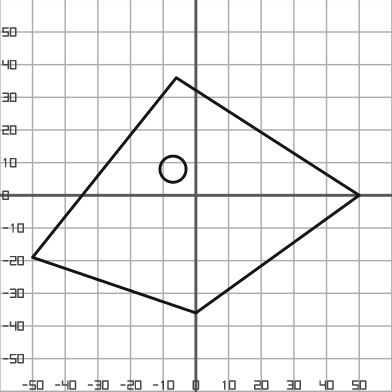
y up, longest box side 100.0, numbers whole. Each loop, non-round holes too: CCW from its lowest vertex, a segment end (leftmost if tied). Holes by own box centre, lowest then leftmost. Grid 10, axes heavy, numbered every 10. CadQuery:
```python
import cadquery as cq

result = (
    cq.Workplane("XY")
    .moveTo(0.0, -36.0)
    .lineTo(50.0, 0.0)
    .lineTo(-6.0, 36.0)
    .lineTo(-50.0, -19.0)
    .close()
    .moveTo(-7.0, 8.0)
    .circle(4.0)
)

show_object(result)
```